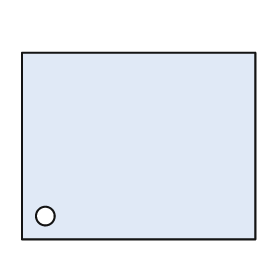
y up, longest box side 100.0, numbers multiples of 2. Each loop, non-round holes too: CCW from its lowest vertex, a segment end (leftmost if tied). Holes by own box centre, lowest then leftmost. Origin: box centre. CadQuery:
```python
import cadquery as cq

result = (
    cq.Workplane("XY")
    .moveTo(-50.0, -40.0)
    .lineTo(50.0, -40.0)
    .lineTo(50.0, 40.0)
    .lineTo(-50.0, 40.0)
    .close()
    .moveTo(-40.0, -30.0)
    .circle(4.0)
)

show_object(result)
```